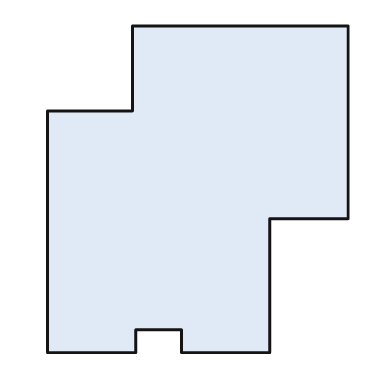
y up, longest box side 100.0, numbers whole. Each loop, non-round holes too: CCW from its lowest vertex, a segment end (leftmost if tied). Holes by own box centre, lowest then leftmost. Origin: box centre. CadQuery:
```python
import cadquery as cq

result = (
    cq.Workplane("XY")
    .moveTo(-46.0, -50.0)
    .lineTo(-19.0, -50.0)
    .lineTo(-19.0, -43.0)
    .lineTo(-5.0, -43.0)
    .lineTo(-5.0, -50.0)
    .lineTo(22.0, -50.0)
    .lineTo(22.0, -9.0)
    .lineTo(46.0, -9.0)
    .lineTo(46.0, 50.0)
    .lineTo(-20.0, 50.0)
    .lineTo(-20.0, 24.0)
    .lineTo(-46.0, 24.0)
    .close()
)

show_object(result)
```